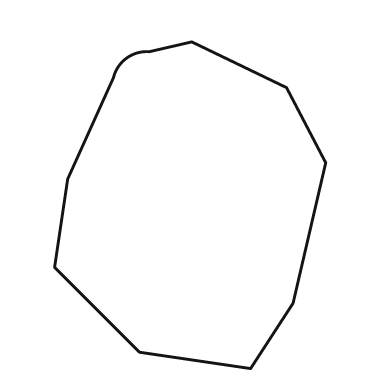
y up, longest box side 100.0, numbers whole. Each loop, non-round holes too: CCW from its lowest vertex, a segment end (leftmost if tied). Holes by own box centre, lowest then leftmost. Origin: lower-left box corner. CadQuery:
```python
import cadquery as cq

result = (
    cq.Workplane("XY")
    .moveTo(60.0, 0.0)
    .lineTo(73.0, 20.0)
    .lineTo(83.0, 63.0)
    .lineTo(71.0, 86.0)
    .lineTo(42.0, 100.0)
    .lineTo(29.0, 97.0)
    .threePointArc((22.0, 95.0), (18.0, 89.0))
    .lineTo(4.0, 58.0)
    .lineTo(0.0, 31.0)
    .lineTo(26.0, 5.0)
    .close()
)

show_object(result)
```